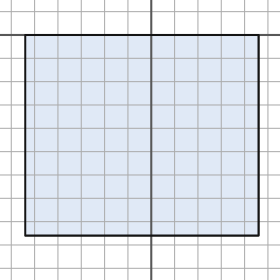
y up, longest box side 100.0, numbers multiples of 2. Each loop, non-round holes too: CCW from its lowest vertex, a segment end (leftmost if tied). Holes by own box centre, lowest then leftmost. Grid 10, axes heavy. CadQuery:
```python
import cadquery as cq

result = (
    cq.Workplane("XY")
    .moveTo(-54.0, -86.0)
    .lineTo(46.0, -86.0)
    .lineTo(46.0, 0.0)
    .lineTo(-54.0, 0.0)
    .close()
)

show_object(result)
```